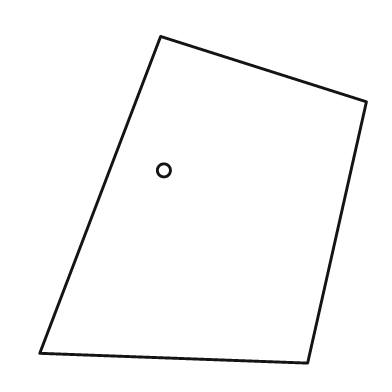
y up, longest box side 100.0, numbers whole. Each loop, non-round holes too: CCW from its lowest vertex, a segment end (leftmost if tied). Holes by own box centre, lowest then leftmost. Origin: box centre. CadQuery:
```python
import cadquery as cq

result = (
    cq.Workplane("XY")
    .moveTo(32.0, -50.0)
    .lineTo(50.0, 30.0)
    .lineTo(-13.0, 50.0)
    .lineTo(-50.0, -47.0)
    .close()
    .moveTo(-12.0, 9.0)
    .circle(2.0)
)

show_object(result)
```